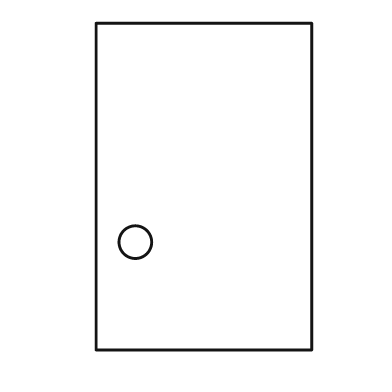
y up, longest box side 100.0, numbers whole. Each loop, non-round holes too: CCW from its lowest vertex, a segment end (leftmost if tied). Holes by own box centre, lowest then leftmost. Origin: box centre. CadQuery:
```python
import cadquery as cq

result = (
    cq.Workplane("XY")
    .moveTo(-33.0, -50.0)
    .lineTo(33.0, -50.0)
    .lineTo(33.0, 50.0)
    .lineTo(-33.0, 50.0)
    .close()
    .moveTo(-21.0, -17.0)
    .circle(5.0)
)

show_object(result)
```